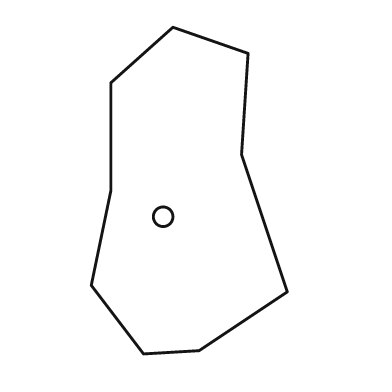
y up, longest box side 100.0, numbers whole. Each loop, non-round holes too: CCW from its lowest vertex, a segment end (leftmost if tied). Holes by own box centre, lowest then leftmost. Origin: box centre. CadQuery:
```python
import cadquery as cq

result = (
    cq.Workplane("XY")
    .moveTo(-14.0, -50.0)
    .lineTo(3.0, -49.0)
    .lineTo(30.0, -31.0)
    .lineTo(16.0, 11.0)
    .lineTo(18.0, 42.0)
    .lineTo(-5.0, 50.0)
    .lineTo(-24.0, 33.0)
    .lineTo(-24.0, 0.0)
    .lineTo(-30.0, -29.0)
    .close()
    .moveTo(-8.0, -8.0)
    .circle(3.0)
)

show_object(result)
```